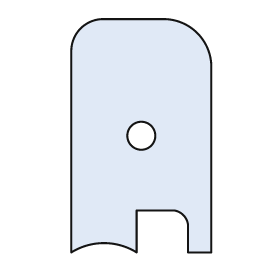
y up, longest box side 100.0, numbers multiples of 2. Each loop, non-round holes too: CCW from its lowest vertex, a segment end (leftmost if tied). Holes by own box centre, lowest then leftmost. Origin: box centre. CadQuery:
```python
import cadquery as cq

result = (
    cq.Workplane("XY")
    .moveTo(-30.0, -50.0)
    .threePointArc((-16.0, -46.0), (-2.0, -50.0))
    .lineTo(-2.0, -32.0)
    .lineTo(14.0, -32.0)
    .threePointArc((18.0, -34.0), (20.0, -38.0))
    .lineTo(20.0, -50.0)
    .lineTo(30.0, -50.0)
    .lineTo(30.0, 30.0)
    .threePointArc((24.0, 44.0), (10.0, 50.0))
    .lineTo(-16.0, 50.0)
    .threePointArc((-26.0, 46.0), (-30.0, 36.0))
    .close()
    .moveTo(0.0, 0.0)
    .circle(6.0)
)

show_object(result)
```